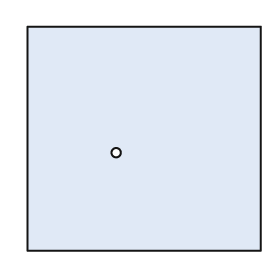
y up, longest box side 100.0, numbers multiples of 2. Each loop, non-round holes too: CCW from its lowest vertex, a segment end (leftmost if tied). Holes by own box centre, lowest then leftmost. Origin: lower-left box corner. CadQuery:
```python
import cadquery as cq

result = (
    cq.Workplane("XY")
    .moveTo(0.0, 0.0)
    .lineTo(100.0, 0.0)
    .lineTo(100.0, 96.0)
    .lineTo(0.0, 96.0)
    .close()
    .moveTo(38.0, 42.0)
    .circle(2.0)
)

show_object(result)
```